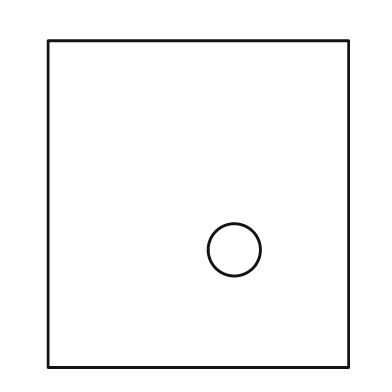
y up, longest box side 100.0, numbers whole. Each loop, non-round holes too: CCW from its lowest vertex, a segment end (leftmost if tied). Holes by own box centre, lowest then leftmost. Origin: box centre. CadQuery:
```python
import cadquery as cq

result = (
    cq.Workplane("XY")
    .moveTo(-46.0, -50.0)
    .lineTo(46.0, -50.0)
    .lineTo(46.0, 50.0)
    .lineTo(-46.0, 50.0)
    .close()
    .moveTo(11.0, -14.0)
    .circle(8.0)
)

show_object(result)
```